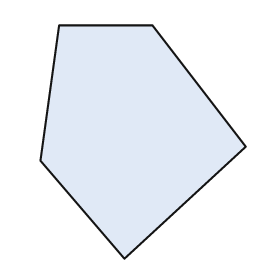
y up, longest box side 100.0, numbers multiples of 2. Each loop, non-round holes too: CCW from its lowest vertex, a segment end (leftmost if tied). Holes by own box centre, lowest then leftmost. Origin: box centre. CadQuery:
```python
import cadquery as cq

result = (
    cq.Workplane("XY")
    .moveTo(-8.0, -50.0)
    .lineTo(44.0, -2.0)
    .lineTo(4.0, 50.0)
    .lineTo(-36.0, 50.0)
    .lineTo(-44.0, -8.0)
    .close()
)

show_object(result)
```